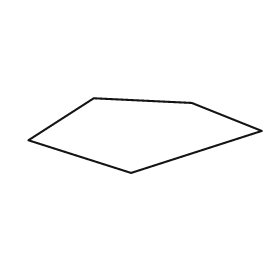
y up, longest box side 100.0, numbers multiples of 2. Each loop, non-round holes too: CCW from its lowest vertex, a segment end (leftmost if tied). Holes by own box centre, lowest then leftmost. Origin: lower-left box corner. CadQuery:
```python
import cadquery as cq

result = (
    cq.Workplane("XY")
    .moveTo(44.0, 0.0)
    .lineTo(100.0, 18.0)
    .lineTo(70.0, 30.0)
    .lineTo(28.0, 32.0)
    .lineTo(0.0, 14.0)
    .close()
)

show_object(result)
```